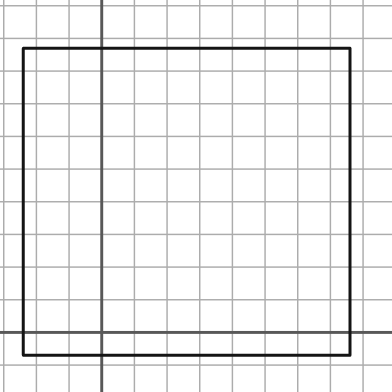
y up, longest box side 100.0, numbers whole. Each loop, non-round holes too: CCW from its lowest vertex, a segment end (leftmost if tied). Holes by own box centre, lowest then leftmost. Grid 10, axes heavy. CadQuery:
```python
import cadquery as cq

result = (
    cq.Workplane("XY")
    .moveTo(-24.0, -7.0)
    .lineTo(76.0, -7.0)
    .lineTo(76.0, 87.0)
    .lineTo(-24.0, 87.0)
    .close()
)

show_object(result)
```